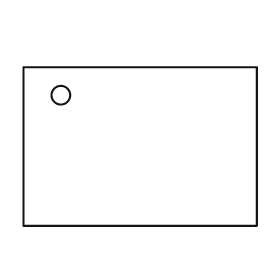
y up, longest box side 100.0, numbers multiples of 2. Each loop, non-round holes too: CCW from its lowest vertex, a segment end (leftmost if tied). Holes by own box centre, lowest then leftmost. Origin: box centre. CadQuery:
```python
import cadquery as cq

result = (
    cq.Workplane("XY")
    .moveTo(-50.0, -34.0)
    .lineTo(50.0, -34.0)
    .lineTo(50.0, 34.0)
    .lineTo(-50.0, 34.0)
    .close()
    .moveTo(-34.0, 22.0)
    .circle(4.0)
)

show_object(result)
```